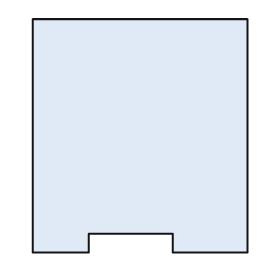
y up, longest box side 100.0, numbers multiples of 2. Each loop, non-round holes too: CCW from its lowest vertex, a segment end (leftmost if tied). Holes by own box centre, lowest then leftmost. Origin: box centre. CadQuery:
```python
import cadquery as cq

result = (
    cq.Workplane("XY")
    .moveTo(-46.0, -50.0)
    .lineTo(-22.0, -50.0)
    .lineTo(-22.0, -42.0)
    .lineTo(14.0, -42.0)
    .lineTo(14.0, -50.0)
    .lineTo(46.0, -50.0)
    .lineTo(46.0, 50.0)
    .lineTo(-46.0, 50.0)
    .close()
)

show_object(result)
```